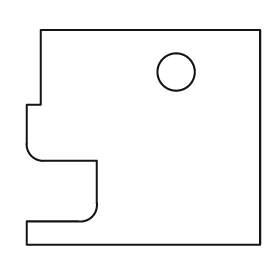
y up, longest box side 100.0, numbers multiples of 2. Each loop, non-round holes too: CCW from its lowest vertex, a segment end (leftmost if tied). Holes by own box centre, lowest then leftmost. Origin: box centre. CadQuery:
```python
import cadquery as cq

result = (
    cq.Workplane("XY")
    .moveTo(-50.0, -46.0)
    .lineTo(50.0, -46.0)
    .lineTo(50.0, 46.0)
    .lineTo(-44.0, 46.0)
    .lineTo(-44.0, 14.0)
    .lineTo(-50.0, 14.0)
    .lineTo(-50.0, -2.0)
    .threePointArc((-48.0, -8.0), (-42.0, -10.0))
    .lineTo(-20.0, -10.0)
    .lineTo(-20.0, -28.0)
    .threePointArc((-22.0, -34.0), (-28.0, -36.0))
    .lineTo(-50.0, -36.0)
    .close()
    .moveTo(14.0, 28.0)
    .circle(8.0)
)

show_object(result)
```